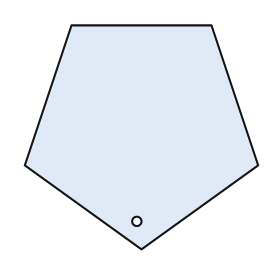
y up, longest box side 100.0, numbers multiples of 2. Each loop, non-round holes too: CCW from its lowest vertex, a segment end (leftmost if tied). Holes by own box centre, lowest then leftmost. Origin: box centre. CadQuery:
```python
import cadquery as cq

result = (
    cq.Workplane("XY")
    .moveTo(0.0, -48.0)
    .lineTo(50.0, -12.0)
    .lineTo(30.0, 48.0)
    .lineTo(-30.0, 48.0)
    .lineTo(-50.0, -12.0)
    .close()
    .moveTo(-2.0, -36.0)
    .circle(2.0)
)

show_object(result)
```